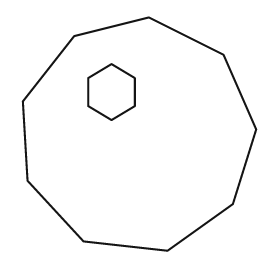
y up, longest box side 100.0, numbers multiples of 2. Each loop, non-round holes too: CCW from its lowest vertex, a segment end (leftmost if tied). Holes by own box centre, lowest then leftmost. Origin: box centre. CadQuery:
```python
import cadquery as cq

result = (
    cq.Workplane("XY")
    .moveTo(12.0, -50.0)
    .lineTo(40.0, -30.0)
    .lineTo(50.0, 2.0)
    .lineTo(36.0, 34.0)
    .lineTo(4.0, 50.0)
    .lineTo(-28.0, 42.0)
    .lineTo(-50.0, 14.0)
    .lineTo(-48.0, -20.0)
    .lineTo(-24.0, -46.0)
    .close()
    .moveTo(-12.0, 6.0)
    .lineTo(-2.0, 12.0)
    .lineTo(-2.0, 24.0)
    .lineTo(-12.0, 30.0)
    .lineTo(-22.0, 24.0)
    .lineTo(-22.0, 12.0)
    .close()
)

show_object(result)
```